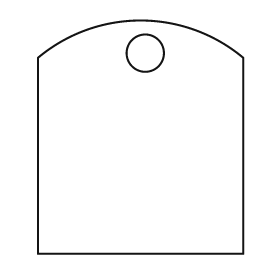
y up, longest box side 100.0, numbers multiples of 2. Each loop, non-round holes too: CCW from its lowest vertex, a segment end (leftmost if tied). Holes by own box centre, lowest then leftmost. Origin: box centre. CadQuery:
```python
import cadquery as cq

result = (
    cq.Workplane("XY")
    .moveTo(-44.0, -50.0)
    .lineTo(44.0, -50.0)
    .lineTo(44.0, 34.0)
    .threePointArc((0.0, 50.0), (-44.0, 34.0))
    .close()
    .moveTo(2.0, 36.0)
    .circle(8.0)
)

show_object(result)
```